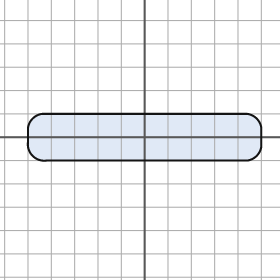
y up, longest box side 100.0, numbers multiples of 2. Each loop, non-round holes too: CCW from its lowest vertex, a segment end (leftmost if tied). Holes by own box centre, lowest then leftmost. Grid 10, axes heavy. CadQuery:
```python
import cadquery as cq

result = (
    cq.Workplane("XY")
    .moveTo(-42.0, -10.0)
    .lineTo(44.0, -10.0)
    .threePointArc((48.0, -8.0), (50.0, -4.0))
    .lineTo(50.0, 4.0)
    .threePointArc((48.0, 8.0), (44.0, 10.0))
    .lineTo(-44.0, 10.0)
    .threePointArc((-48.0, 8.0), (-50.0, 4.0))
    .lineTo(-50.0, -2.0)
    .threePointArc((-48.0, -8.0), (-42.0, -10.0))
    .close()
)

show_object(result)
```